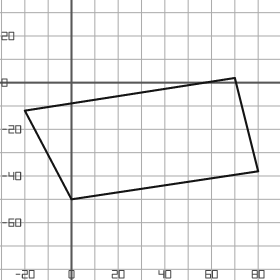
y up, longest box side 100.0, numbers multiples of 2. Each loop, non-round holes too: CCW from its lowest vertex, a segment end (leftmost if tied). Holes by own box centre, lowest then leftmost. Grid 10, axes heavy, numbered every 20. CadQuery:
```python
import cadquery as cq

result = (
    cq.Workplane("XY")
    .moveTo(0.0, -50.0)
    .lineTo(80.0, -38.0)
    .lineTo(70.0, 2.0)
    .lineTo(-20.0, -12.0)
    .close()
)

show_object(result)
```